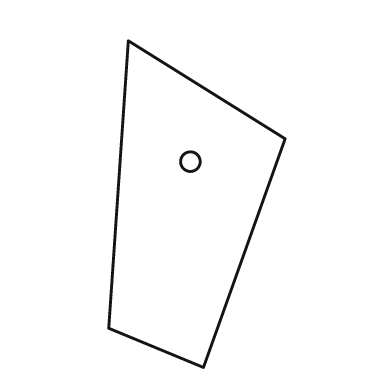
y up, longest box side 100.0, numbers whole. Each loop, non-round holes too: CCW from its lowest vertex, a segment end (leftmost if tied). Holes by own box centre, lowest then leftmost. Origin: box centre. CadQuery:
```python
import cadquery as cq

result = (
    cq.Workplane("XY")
    .moveTo(2.0, -50.0)
    .lineTo(27.0, 20.0)
    .lineTo(-21.0, 50.0)
    .lineTo(-27.0, -38.0)
    .close()
    .moveTo(-2.0, 13.0)
    .circle(3.0)
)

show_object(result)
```